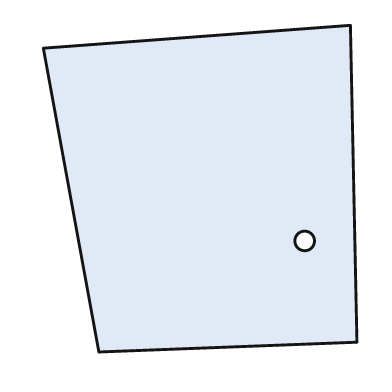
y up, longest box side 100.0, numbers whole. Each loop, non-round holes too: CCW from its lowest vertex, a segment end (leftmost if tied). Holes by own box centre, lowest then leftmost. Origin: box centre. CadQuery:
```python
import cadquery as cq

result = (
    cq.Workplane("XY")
    .moveTo(-31.0, -50.0)
    .lineTo(48.0, -47.0)
    .lineTo(46.0, 50.0)
    .lineTo(-48.0, 43.0)
    .close()
    .moveTo(32.0, -16.0)
    .circle(3.0)
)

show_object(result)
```